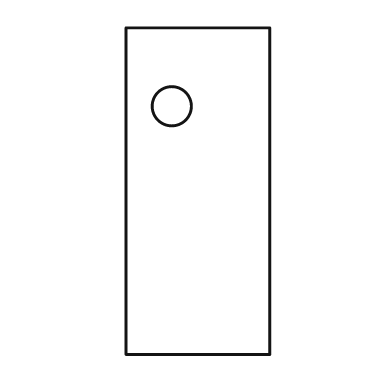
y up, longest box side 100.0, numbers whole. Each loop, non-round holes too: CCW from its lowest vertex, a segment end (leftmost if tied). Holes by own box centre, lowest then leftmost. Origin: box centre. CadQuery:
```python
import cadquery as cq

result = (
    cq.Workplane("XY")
    .moveTo(-22.0, -50.0)
    .lineTo(22.0, -50.0)
    .lineTo(22.0, 50.0)
    .lineTo(-22.0, 50.0)
    .close()
    .moveTo(-8.0, 26.0)
    .circle(6.0)
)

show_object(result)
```